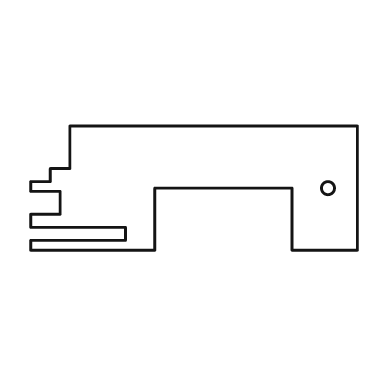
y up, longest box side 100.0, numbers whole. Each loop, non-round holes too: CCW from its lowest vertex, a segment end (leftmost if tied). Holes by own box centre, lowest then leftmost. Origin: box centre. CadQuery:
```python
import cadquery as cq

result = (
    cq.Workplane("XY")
    .moveTo(-50.0, -19.0)
    .lineTo(-12.0, -19.0)
    .lineTo(-12.0, 0.0)
    .lineTo(30.0, 0.0)
    .lineTo(30.0, -19.0)
    .lineTo(50.0, -19.0)
    .lineTo(50.0, 19.0)
    .lineTo(-38.0, 19.0)
    .lineTo(-38.0, 6.0)
    .lineTo(-44.0, 6.0)
    .lineTo(-44.0, 2.0)
    .lineTo(-50.0, 2.0)
    .lineTo(-50.0, -1.0)
    .lineTo(-41.0, -1.0)
    .lineTo(-41.0, -8.0)
    .lineTo(-50.0, -8.0)
    .lineTo(-50.0, -12.0)
    .lineTo(-21.0, -12.0)
    .lineTo(-21.0, -16.0)
    .lineTo(-50.0, -16.0)
    .close()
    .moveTo(41.0, 0.0)
    .circle(2.0)
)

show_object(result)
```